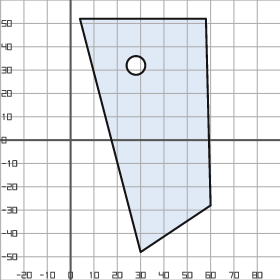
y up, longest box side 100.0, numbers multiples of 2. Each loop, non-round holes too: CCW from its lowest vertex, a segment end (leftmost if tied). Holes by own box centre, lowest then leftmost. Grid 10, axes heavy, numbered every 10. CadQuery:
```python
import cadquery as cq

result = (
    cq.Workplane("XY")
    .moveTo(30.0, -48.0)
    .lineTo(60.0, -28.0)
    .lineTo(58.0, 52.0)
    .lineTo(4.0, 52.0)
    .close()
    .moveTo(28.0, 32.0)
    .circle(4.0)
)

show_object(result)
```